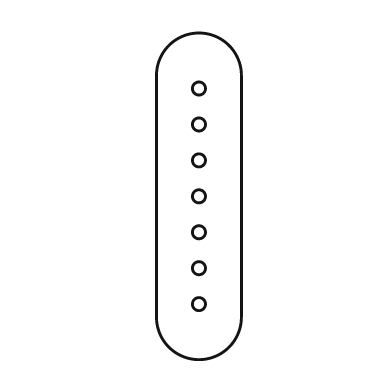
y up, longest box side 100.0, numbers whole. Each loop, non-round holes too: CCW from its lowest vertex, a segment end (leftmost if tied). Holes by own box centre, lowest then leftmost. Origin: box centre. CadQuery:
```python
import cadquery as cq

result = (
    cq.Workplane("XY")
    .moveTo(-13.0, -37.0)
    .threePointArc((0.0, -50.0), (13.0, -37.0))
    .lineTo(13.0, 37.0)
    .threePointArc((0.0, 50.0), (-13.0, 37.0))
    .close()
    .moveTo(0.0, -33.0)
    .circle(2.0)
    .moveTo(0.0, -22.0)
    .circle(2.0)
    .moveTo(0.0, -11.0)
    .circle(2.0)
    .moveTo(0.0, 0.0)
    .circle(2.0)
    .moveTo(0.0, 11.0)
    .circle(2.0)
    .moveTo(0.0, 22.0)
    .circle(2.0)
    .moveTo(0.0, 33.0)
    .circle(2.0)
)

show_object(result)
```